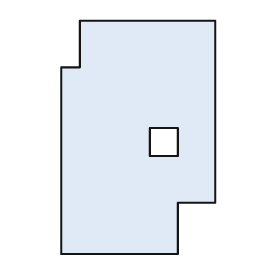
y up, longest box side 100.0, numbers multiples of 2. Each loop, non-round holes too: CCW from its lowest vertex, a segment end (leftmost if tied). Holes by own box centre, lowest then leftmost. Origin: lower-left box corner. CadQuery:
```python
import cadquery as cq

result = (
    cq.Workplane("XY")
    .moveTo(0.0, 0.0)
    .lineTo(50.0, 0.0)
    .lineTo(50.0, 22.0)
    .lineTo(66.0, 22.0)
    .lineTo(66.0, 100.0)
    .lineTo(8.0, 100.0)
    .lineTo(8.0, 80.0)
    .lineTo(0.0, 80.0)
    .close()
    .moveTo(38.0, 42.0)
    .lineTo(50.0, 42.0)
    .lineTo(50.0, 54.0)
    .lineTo(38.0, 54.0)
    .close()
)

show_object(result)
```